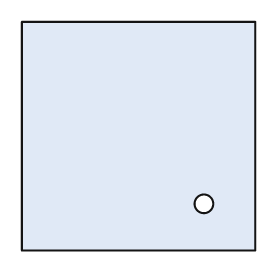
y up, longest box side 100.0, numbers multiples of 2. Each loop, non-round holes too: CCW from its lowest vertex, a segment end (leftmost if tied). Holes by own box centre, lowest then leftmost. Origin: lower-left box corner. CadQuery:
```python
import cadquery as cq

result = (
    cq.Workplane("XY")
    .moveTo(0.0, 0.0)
    .lineTo(100.0, 0.0)
    .lineTo(100.0, 98.0)
    .lineTo(0.0, 98.0)
    .close()
    .moveTo(78.0, 20.0)
    .circle(4.0)
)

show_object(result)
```